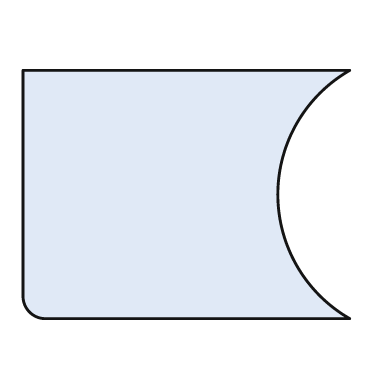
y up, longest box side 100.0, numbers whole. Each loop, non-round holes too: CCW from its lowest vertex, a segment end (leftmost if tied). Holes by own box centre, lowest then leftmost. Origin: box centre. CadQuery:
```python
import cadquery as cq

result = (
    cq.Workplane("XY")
    .moveTo(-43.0, -38.0)
    .lineTo(50.0, -38.0)
    .threePointArc((28.0, 0.0), (50.0, 38.0))
    .lineTo(-50.0, 38.0)
    .lineTo(-50.0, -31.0)
    .threePointArc((-48.0, -36.0), (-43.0, -38.0))
    .close()
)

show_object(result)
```